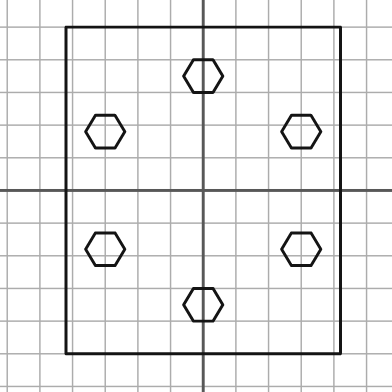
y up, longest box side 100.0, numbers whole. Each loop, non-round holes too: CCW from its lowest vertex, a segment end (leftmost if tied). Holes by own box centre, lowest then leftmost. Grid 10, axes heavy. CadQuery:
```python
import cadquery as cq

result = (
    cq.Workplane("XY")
    .moveTo(-42.0, -50.0)
    .lineTo(42.0, -50.0)
    .lineTo(42.0, 50.0)
    .lineTo(-42.0, 50.0)
    .close()
    .moveTo(-3.0, -40.0)
    .lineTo(3.0, -40.0)
    .lineTo(6.0, -35.0)
    .lineTo(3.0, -30.0)
    .lineTo(-3.0, -30.0)
    .lineTo(-6.0, -35.0)
    .close()
    .moveTo(-33.0, -23.0)
    .lineTo(-27.0, -23.0)
    .lineTo(-24.0, -18.0)
    .lineTo(-27.0, -13.0)
    .lineTo(-33.0, -13.0)
    .lineTo(-36.0, -18.0)
    .close()
    .moveTo(27.0, -23.0)
    .lineTo(33.0, -23.0)
    .lineTo(36.0, -18.0)
    .lineTo(33.0, -13.0)
    .lineTo(27.0, -13.0)
    .lineTo(24.0, -18.0)
    .close()
    .moveTo(-33.0, 13.0)
    .lineTo(-27.0, 13.0)
    .lineTo(-24.0, 18.0)
    .lineTo(-27.0, 23.0)
    .lineTo(-33.0, 23.0)
    .lineTo(-36.0, 18.0)
    .close()
    .moveTo(27.0, 13.0)
    .lineTo(33.0, 13.0)
    .lineTo(36.0, 18.0)
    .lineTo(33.0, 23.0)
    .lineTo(27.0, 23.0)
    .lineTo(24.0, 18.0)
    .close()
    .moveTo(-3.0, 30.0)
    .lineTo(3.0, 30.0)
    .lineTo(6.0, 35.0)
    .lineTo(3.0, 40.0)
    .lineTo(-3.0, 40.0)
    .lineTo(-6.0, 35.0)
    .close()
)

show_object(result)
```